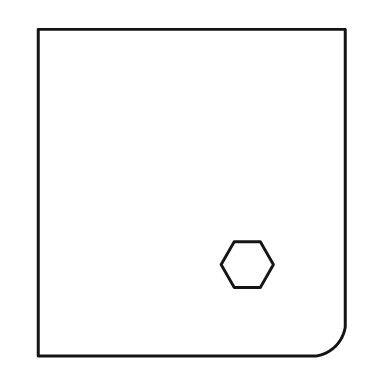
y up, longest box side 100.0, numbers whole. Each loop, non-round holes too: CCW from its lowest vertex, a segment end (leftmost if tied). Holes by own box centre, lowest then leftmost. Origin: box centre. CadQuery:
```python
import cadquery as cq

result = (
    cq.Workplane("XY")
    .moveTo(-47.0, -50.0)
    .lineTo(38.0, -50.0)
    .threePointArc((44.0, -47.0), (47.0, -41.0))
    .lineTo(47.0, 50.0)
    .lineTo(-47.0, 50.0)
    .close()
    .moveTo(13.0, -29.0)
    .lineTo(21.0, -29.0)
    .lineTo(25.0, -22.0)
    .lineTo(21.0, -15.0)
    .lineTo(13.0, -15.0)
    .lineTo(9.0, -22.0)
    .close()
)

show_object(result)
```